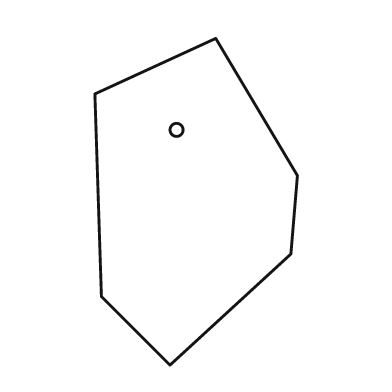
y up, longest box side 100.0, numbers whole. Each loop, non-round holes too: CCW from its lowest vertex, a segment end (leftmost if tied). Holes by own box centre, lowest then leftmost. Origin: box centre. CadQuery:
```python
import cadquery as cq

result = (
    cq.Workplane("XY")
    .moveTo(-8.0, -50.0)
    .lineTo(29.0, -16.0)
    .lineTo(31.0, 8.0)
    .lineTo(6.0, 50.0)
    .lineTo(-31.0, 33.0)
    .lineTo(-29.0, -29.0)
    .close()
    .moveTo(-6.0, 22.0)
    .circle(2.0)
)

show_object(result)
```